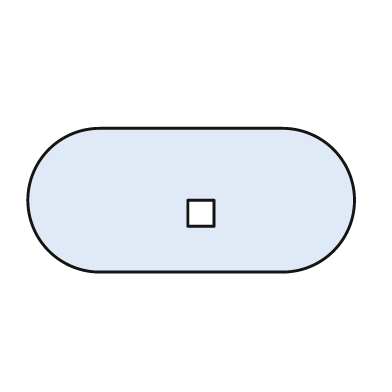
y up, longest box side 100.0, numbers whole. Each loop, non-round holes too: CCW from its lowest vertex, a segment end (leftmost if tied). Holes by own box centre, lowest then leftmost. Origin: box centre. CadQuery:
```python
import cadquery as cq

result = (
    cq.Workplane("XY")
    .moveTo(-28.0, -22.0)
    .lineTo(28.0, -22.0)
    .threePointArc((50.0, 0.0), (28.0, 22.0))
    .lineTo(-28.0, 22.0)
    .threePointArc((-50.0, 0.0), (-28.0, -22.0))
    .close()
    .moveTo(-1.0, -8.0)
    .lineTo(7.0, -8.0)
    .lineTo(7.0, 0.0)
    .lineTo(-1.0, 0.0)
    .close()
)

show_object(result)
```